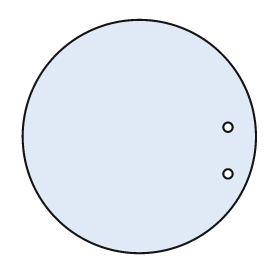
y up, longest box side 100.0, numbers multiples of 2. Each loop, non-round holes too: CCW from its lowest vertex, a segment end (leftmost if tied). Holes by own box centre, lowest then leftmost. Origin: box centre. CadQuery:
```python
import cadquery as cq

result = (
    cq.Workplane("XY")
    .moveTo(0.0, 0.0)
    .circle(50.0)
    .moveTo(38.0, -16.0)
    .circle(2.0)
    .moveTo(38.0, 4.0)
    .circle(2.0)
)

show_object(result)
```